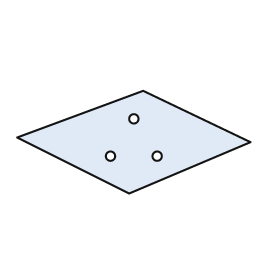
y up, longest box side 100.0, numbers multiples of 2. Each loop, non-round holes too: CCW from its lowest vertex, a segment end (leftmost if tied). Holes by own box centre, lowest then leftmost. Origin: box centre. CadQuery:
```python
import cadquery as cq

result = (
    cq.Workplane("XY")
    .moveTo(-2.0, -22.0)
    .lineTo(50.0, 0.0)
    .lineTo(4.0, 22.0)
    .lineTo(-50.0, 2.0)
    .close()
    .moveTo(-10.0, -6.0)
    .circle(2.0)
    .moveTo(10.0, -6.0)
    .circle(2.0)
    .moveTo(0.0, 10.0)
    .circle(2.0)
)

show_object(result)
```